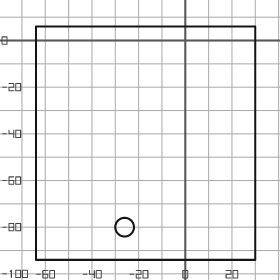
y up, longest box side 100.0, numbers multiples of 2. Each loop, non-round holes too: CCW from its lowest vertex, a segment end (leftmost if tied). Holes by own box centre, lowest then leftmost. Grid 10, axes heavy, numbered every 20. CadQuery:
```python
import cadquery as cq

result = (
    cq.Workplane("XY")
    .moveTo(-64.0, -94.0)
    .lineTo(30.0, -94.0)
    .lineTo(30.0, 6.0)
    .lineTo(-64.0, 6.0)
    .close()
    .moveTo(-26.0, -80.0)
    .circle(4.0)
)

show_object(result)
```